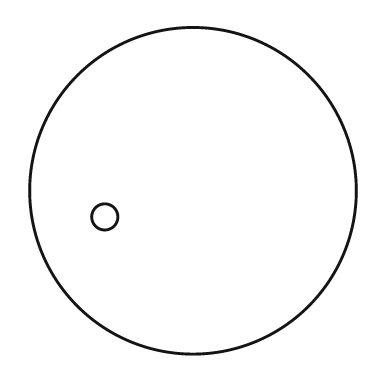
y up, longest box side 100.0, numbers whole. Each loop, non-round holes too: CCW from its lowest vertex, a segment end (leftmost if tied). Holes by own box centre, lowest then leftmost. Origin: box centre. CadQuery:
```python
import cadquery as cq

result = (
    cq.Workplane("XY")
    .moveTo(0.0, 0.0)
    .circle(50.0)
    .moveTo(-27.0, -8.0)
    .circle(4.0)
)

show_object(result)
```